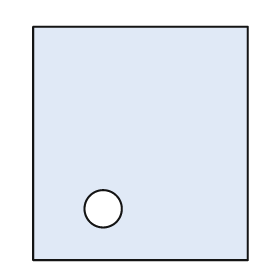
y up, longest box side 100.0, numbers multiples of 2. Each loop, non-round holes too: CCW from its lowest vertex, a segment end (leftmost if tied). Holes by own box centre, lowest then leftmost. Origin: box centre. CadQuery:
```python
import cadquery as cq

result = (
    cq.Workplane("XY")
    .moveTo(-46.0, -50.0)
    .lineTo(46.0, -50.0)
    .lineTo(46.0, 50.0)
    .lineTo(-46.0, 50.0)
    .close()
    .moveTo(-16.0, -28.0)
    .circle(8.0)
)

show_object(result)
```